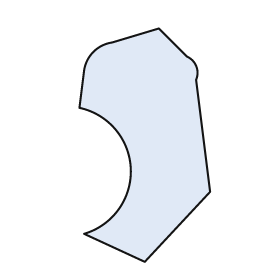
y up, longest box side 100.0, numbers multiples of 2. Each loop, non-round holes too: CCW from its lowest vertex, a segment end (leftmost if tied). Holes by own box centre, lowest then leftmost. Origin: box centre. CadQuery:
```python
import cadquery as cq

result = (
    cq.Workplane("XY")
    .moveTo(0.0, -50.0)
    .lineTo(28.0, -20.0)
    .lineTo(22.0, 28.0)
    .threePointArc((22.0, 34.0), (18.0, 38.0))
    .lineTo(6.0, 50.0)
    .lineTo(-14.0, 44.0)
    .threePointArc((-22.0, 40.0), (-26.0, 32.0))
    .lineTo(-28.0, 16.0)
    .threePointArc((-6.0, -10.0), (-26.0, -38.0))
    .close()
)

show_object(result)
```